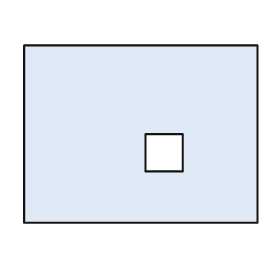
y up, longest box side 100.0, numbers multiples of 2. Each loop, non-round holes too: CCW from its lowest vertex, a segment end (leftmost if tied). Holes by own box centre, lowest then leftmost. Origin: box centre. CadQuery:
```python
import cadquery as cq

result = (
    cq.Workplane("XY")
    .moveTo(-50.0, -38.0)
    .lineTo(50.0, -38.0)
    .lineTo(50.0, 38.0)
    .lineTo(-50.0, 38.0)
    .close()
    .moveTo(2.0, -16.0)
    .lineTo(18.0, -16.0)
    .lineTo(18.0, 0.0)
    .lineTo(2.0, 0.0)
    .close()
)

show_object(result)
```